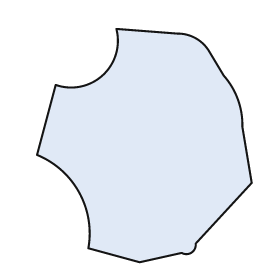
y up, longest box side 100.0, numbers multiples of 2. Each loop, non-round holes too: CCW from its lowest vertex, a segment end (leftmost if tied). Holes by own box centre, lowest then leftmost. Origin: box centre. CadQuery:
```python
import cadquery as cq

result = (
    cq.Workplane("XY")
    .moveTo(-2.0, -50.0)
    .lineTo(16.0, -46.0)
    .threePointArc((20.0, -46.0), (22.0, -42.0))
    .lineTo(46.0, -16.0)
    .lineTo(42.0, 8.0)
    .threePointArc((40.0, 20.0), (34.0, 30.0))
    .lineTo(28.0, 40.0)
    .threePointArc((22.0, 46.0), (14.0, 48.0))
    .lineTo(-12.0, 50.0)
    .threePointArc((-18.0, 30.0), (-38.0, 26.0))
    .lineTo(-46.0, -4.0)
    .threePointArc((-28.0, -20.0), (-24.0, -44.0))
    .close()
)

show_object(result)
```